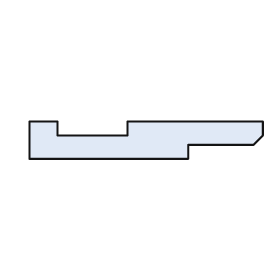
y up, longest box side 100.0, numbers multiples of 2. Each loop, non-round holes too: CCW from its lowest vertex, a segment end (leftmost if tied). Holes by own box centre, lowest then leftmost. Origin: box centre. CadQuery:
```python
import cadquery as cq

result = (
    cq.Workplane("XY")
    .moveTo(-50.0, -8.0)
    .lineTo(18.0, -8.0)
    .lineTo(18.0, -2.0)
    .lineTo(46.0, -2.0)
    .lineTo(50.0, 2.0)
    .lineTo(50.0, 8.0)
    .lineTo(-8.0, 8.0)
    .lineTo(-8.0, 2.0)
    .lineTo(-38.0, 2.0)
    .lineTo(-38.0, 8.0)
    .lineTo(-50.0, 8.0)
    .close()
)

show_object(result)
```